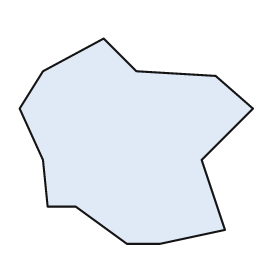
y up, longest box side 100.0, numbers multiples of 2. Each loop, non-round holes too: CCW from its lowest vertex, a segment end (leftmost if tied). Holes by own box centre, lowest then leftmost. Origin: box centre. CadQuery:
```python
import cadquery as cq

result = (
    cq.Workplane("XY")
    .moveTo(-4.0, -44.0)
    .lineTo(10.0, -44.0)
    .lineTo(38.0, -38.0)
    .lineTo(28.0, -8.0)
    .lineTo(50.0, 14.0)
    .lineTo(34.0, 28.0)
    .lineTo(0.0, 30.0)
    .lineTo(-14.0, 44.0)
    .lineTo(-40.0, 30.0)
    .lineTo(-50.0, 14.0)
    .lineTo(-40.0, -8.0)
    .lineTo(-38.0, -28.0)
    .lineTo(-26.0, -28.0)
    .close()
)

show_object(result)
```